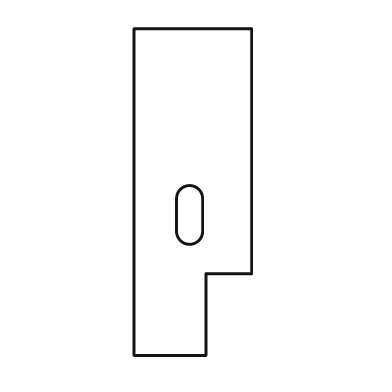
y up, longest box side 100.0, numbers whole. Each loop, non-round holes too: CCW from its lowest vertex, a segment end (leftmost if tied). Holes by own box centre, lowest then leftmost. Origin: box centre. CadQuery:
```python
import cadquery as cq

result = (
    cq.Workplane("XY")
    .moveTo(-18.0, -50.0)
    .lineTo(4.0, -50.0)
    .lineTo(4.0, -25.0)
    .lineTo(18.0, -25.0)
    .lineTo(18.0, 50.0)
    .lineTo(-18.0, 50.0)
    .close()
    .moveTo(-5.0, -12.0)
    .threePointArc((-1.0, -16.0), (3.0, -12.0))
    .lineTo(3.0, -2.0)
    .threePointArc((-1.0, 2.0), (-5.0, -2.0))
    .close()
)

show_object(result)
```